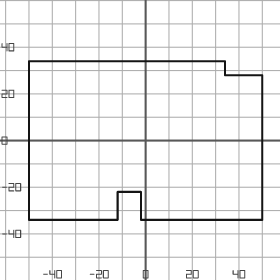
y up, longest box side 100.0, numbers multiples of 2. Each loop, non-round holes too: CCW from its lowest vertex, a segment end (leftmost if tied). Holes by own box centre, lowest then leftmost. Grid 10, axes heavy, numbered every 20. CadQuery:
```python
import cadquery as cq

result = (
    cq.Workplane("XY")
    .moveTo(-50.0, -34.0)
    .lineTo(-12.0, -34.0)
    .lineTo(-12.0, -22.0)
    .lineTo(-2.0, -22.0)
    .lineTo(-2.0, -34.0)
    .lineTo(50.0, -34.0)
    .lineTo(50.0, 28.0)
    .lineTo(34.0, 28.0)
    .lineTo(34.0, 34.0)
    .lineTo(-50.0, 34.0)
    .close()
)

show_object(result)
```